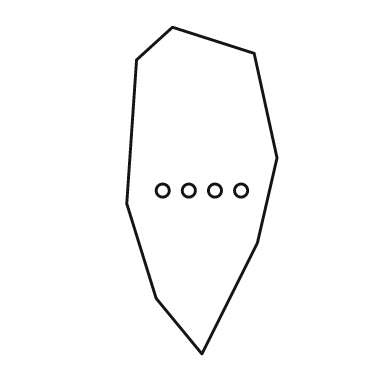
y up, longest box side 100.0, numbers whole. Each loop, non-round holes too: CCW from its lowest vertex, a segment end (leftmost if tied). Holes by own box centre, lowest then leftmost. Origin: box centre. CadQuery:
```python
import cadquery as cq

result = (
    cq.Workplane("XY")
    .moveTo(0.0, -50.0)
    .lineTo(17.0, -16.0)
    .lineTo(23.0, 10.0)
    .lineTo(16.0, 42.0)
    .lineTo(-9.0, 50.0)
    .lineTo(-20.0, 40.0)
    .lineTo(-23.0, -4.0)
    .lineTo(-14.0, -33.0)
    .close()
    .moveTo(-12.0, 0.0)
    .circle(2.0)
    .moveTo(-4.0, 0.0)
    .circle(2.0)
    .moveTo(4.0, 0.0)
    .circle(2.0)
    .moveTo(12.0, 0.0)
    .circle(2.0)
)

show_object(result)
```